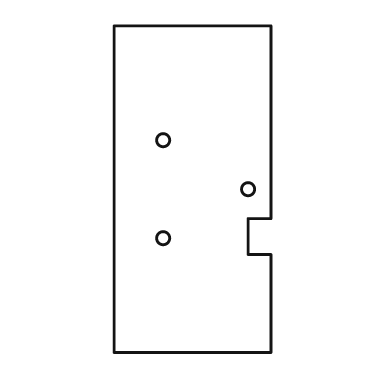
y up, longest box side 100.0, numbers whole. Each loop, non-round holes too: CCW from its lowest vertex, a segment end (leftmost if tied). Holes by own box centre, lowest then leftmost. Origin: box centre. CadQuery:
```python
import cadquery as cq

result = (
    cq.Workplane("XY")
    .moveTo(-24.0, -50.0)
    .lineTo(24.0, -50.0)
    .lineTo(24.0, -20.0)
    .lineTo(17.0, -20.0)
    .lineTo(17.0, -9.0)
    .lineTo(24.0, -9.0)
    .lineTo(24.0, 50.0)
    .lineTo(-24.0, 50.0)
    .close()
    .moveTo(-9.0, -15.0)
    .circle(2.0)
    .moveTo(17.0, 0.0)
    .circle(2.0)
    .moveTo(-9.0, 15.0)
    .circle(2.0)
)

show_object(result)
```